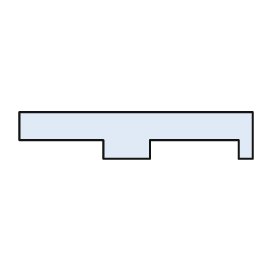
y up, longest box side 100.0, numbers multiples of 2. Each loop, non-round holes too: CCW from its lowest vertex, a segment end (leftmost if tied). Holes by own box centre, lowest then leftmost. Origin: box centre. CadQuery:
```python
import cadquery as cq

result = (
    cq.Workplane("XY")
    .moveTo(-14.0, -10.0)
    .lineTo(6.0, -10.0)
    .lineTo(6.0, -2.0)
    .lineTo(44.0, -2.0)
    .lineTo(44.0, -10.0)
    .lineTo(50.0, -10.0)
    .lineTo(50.0, 10.0)
    .lineTo(-50.0, 10.0)
    .lineTo(-50.0, -2.0)
    .lineTo(-14.0, -2.0)
    .close()
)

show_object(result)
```